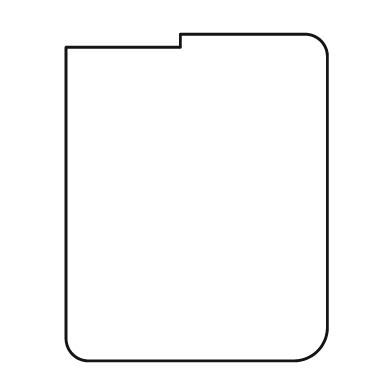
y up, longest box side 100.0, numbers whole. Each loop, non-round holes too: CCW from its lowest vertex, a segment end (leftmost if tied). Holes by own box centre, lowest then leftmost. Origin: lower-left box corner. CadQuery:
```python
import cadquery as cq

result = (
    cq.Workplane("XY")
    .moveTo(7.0, 0.0)
    .lineTo(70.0, 0.0)
    .threePointArc((77.0, 3.0), (80.0, 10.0))
    .lineTo(80.0, 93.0)
    .threePointArc((78.0, 98.0), (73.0, 100.0))
    .lineTo(35.0, 100.0)
    .lineTo(35.0, 96.0)
    .lineTo(0.0, 96.0)
    .lineTo(0.0, 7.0)
    .threePointArc((2.0, 2.0), (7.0, 0.0))
    .close()
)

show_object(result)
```